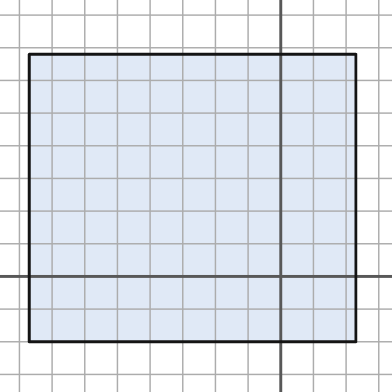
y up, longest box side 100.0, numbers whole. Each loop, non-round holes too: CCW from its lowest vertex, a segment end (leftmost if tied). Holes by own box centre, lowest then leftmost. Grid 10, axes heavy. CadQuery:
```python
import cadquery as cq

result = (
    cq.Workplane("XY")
    .moveTo(-77.0, -20.0)
    .lineTo(23.0, -20.0)
    .lineTo(23.0, 68.0)
    .lineTo(-77.0, 68.0)
    .close()
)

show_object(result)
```